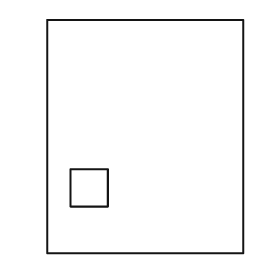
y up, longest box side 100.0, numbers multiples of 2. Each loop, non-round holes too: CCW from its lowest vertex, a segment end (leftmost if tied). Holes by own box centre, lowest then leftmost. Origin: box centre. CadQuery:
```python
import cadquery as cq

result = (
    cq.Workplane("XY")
    .moveTo(-42.0, -50.0)
    .lineTo(42.0, -50.0)
    .lineTo(42.0, 50.0)
    .lineTo(-42.0, 50.0)
    .close()
    .moveTo(-32.0, -30.0)
    .lineTo(-16.0, -30.0)
    .lineTo(-16.0, -14.0)
    .lineTo(-32.0, -14.0)
    .close()
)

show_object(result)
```